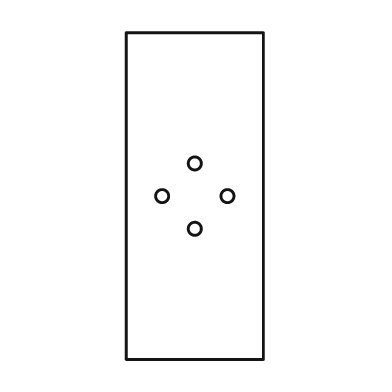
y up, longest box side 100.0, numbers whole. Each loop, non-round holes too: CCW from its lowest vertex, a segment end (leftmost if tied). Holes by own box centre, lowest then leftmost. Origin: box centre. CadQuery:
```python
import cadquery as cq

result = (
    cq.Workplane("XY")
    .moveTo(-21.0, -50.0)
    .lineTo(21.0, -50.0)
    .lineTo(21.0, 50.0)
    .lineTo(-21.0, 50.0)
    .close()
    .moveTo(0.0, -10.0)
    .circle(2.0)
    .moveTo(-10.0, 0.0)
    .circle(2.0)
    .moveTo(10.0, 0.0)
    .circle(2.0)
    .moveTo(0.0, 10.0)
    .circle(2.0)
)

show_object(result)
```